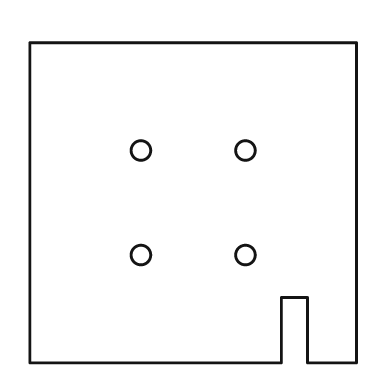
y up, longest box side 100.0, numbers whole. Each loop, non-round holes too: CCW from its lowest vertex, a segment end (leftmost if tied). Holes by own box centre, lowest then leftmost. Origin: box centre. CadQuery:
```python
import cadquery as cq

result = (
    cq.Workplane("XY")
    .moveTo(-50.0, -49.0)
    .lineTo(27.0, -49.0)
    .lineTo(27.0, -29.0)
    .lineTo(35.0, -29.0)
    .lineTo(35.0, -49.0)
    .lineTo(50.0, -49.0)
    .lineTo(50.0, 49.0)
    .lineTo(-50.0, 49.0)
    .close()
    .moveTo(-16.0, -16.0)
    .circle(3.0)
    .moveTo(16.0, -16.0)
    .circle(3.0)
    .moveTo(-16.0, 16.0)
    .circle(3.0)
    .moveTo(16.0, 16.0)
    .circle(3.0)
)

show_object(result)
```